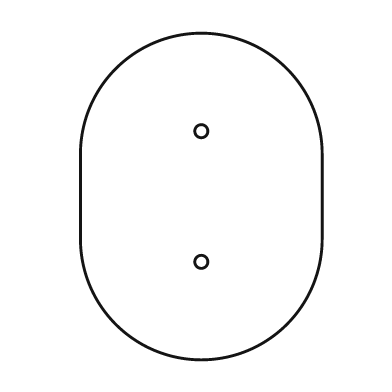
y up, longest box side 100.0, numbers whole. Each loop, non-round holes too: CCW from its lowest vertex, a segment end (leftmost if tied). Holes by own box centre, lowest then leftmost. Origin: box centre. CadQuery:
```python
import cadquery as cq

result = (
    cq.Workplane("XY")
    .moveTo(-37.0, -13.0)
    .threePointArc((0.0, -50.0), (37.0, -13.0))
    .lineTo(37.0, 13.0)
    .threePointArc((0.0, 50.0), (-37.0, 13.0))
    .close()
    .moveTo(0.0, -20.0)
    .circle(2.0)
    .moveTo(0.0, 20.0)
    .circle(2.0)
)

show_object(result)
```